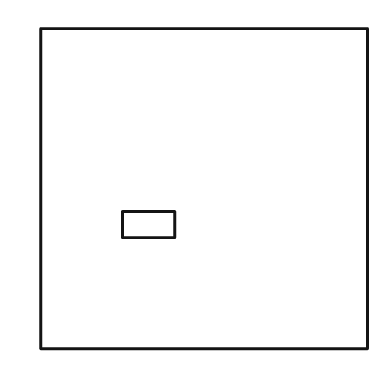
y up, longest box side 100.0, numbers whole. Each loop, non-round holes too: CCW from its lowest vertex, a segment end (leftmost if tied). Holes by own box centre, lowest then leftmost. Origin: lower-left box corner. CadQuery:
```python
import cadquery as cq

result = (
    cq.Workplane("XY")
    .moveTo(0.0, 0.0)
    .lineTo(100.0, 0.0)
    .lineTo(100.0, 98.0)
    .lineTo(0.0, 98.0)
    .close()
    .moveTo(25.0, 34.0)
    .lineTo(41.0, 34.0)
    .lineTo(41.0, 42.0)
    .lineTo(25.0, 42.0)
    .close()
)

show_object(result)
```